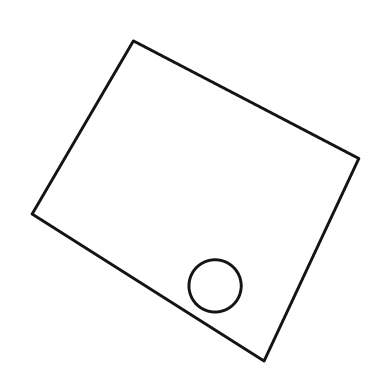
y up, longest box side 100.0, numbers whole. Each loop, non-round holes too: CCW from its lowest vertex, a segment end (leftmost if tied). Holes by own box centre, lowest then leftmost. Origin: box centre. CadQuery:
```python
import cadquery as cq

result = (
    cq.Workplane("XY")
    .moveTo(21.0, -49.0)
    .lineTo(50.0, 13.0)
    .lineTo(-19.0, 49.0)
    .lineTo(-50.0, -4.0)
    .close()
    .moveTo(6.0, -26.0)
    .circle(8.0)
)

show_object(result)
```